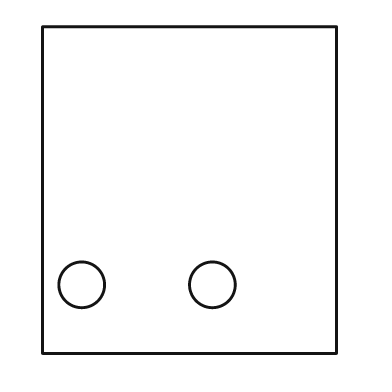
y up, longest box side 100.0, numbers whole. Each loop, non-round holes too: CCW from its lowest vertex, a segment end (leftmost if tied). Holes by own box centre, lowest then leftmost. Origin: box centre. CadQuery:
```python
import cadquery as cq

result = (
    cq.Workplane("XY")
    .moveTo(-45.0, -50.0)
    .lineTo(45.0, -50.0)
    .lineTo(45.0, 50.0)
    .lineTo(-45.0, 50.0)
    .close()
    .moveTo(-33.0, -29.0)
    .circle(7.0)
    .moveTo(7.0, -29.0)
    .circle(7.0)
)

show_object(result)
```